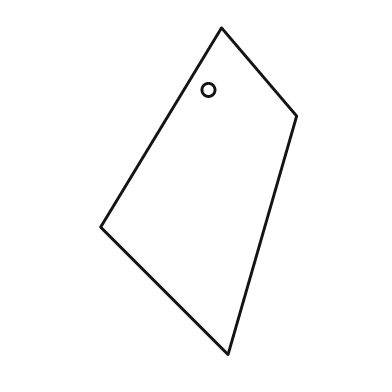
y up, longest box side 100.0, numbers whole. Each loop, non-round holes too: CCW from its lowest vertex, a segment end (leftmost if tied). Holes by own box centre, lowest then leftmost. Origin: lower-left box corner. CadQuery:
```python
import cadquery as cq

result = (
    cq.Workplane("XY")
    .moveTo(39.0, 0.0)
    .lineTo(60.0, 73.0)
    .lineTo(37.0, 100.0)
    .lineTo(0.0, 39.0)
    .close()
    .moveTo(33.0, 81.0)
    .circle(2.0)
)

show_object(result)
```